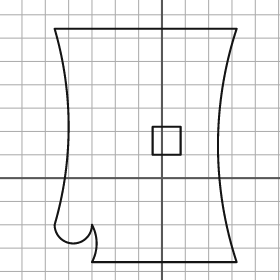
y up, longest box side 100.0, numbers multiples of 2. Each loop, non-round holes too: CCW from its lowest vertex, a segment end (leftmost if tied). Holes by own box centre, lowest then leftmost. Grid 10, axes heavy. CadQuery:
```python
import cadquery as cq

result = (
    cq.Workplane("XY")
    .moveTo(-30.0, -36.0)
    .lineTo(32.0, -36.0)
    .threePointArc((24.0, 14.0), (32.0, 64.0))
    .lineTo(-46.0, 64.0)
    .threePointArc((-40.0, 22.0), (-46.0, -20.0))
    .threePointArc((-38.0, -28.0), (-30.0, -20.0))
    .threePointArc((-28.0, -28.0), (-30.0, -36.0))
    .close()
    .moveTo(-4.0, 10.0)
    .lineTo(8.0, 10.0)
    .lineTo(8.0, 22.0)
    .lineTo(-4.0, 22.0)
    .close()
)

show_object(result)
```